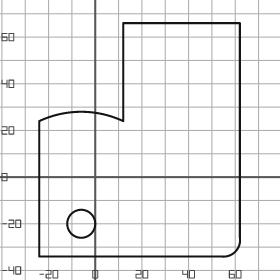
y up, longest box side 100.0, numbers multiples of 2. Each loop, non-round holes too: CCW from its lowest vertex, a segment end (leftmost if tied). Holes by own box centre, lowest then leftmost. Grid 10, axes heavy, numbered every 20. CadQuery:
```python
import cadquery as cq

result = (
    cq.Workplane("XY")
    .moveTo(-24.0, -34.0)
    .lineTo(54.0, -34.0)
    .threePointArc((60.0, -32.0), (62.0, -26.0))
    .lineTo(62.0, 66.0)
    .lineTo(12.0, 66.0)
    .lineTo(12.0, 24.0)
    .threePointArc((-6.0, 28.0), (-24.0, 24.0))
    .close()
    .moveTo(-6.0, -20.0)
    .circle(6.0)
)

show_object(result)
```